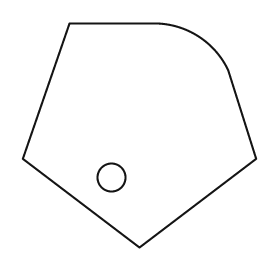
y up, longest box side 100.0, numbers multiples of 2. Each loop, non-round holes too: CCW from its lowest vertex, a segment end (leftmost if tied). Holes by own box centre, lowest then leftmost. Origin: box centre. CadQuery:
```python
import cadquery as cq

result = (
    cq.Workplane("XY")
    .moveTo(0.0, -48.0)
    .lineTo(50.0, -10.0)
    .lineTo(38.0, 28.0)
    .threePointArc((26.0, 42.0), (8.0, 48.0))
    .lineTo(-30.0, 48.0)
    .lineTo(-50.0, -10.0)
    .close()
    .moveTo(-12.0, -18.0)
    .circle(6.0)
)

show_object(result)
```